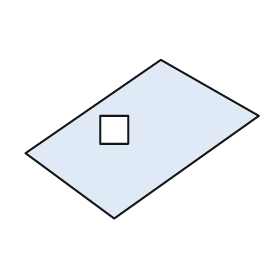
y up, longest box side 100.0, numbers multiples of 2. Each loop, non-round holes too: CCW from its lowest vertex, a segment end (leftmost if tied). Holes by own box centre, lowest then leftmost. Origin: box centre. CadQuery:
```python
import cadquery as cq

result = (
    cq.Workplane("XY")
    .moveTo(-12.0, -34.0)
    .lineTo(50.0, 10.0)
    .lineTo(8.0, 34.0)
    .lineTo(-50.0, -6.0)
    .close()
    .moveTo(-18.0, -2.0)
    .lineTo(-6.0, -2.0)
    .lineTo(-6.0, 10.0)
    .lineTo(-18.0, 10.0)
    .close()
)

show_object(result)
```